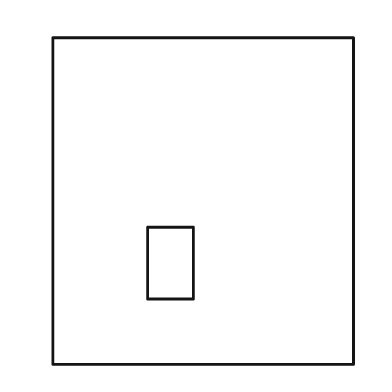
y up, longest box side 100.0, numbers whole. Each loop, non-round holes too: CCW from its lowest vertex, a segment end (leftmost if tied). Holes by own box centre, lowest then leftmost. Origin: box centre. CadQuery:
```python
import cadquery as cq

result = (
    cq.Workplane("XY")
    .moveTo(-46.0, -50.0)
    .lineTo(46.0, -50.0)
    .lineTo(46.0, 50.0)
    .lineTo(-46.0, 50.0)
    .close()
    .moveTo(-17.0, -30.0)
    .lineTo(-3.0, -30.0)
    .lineTo(-3.0, -8.0)
    .lineTo(-17.0, -8.0)
    .close()
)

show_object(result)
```